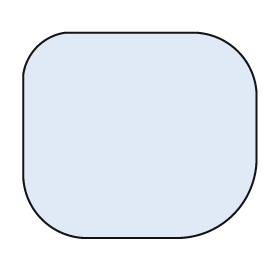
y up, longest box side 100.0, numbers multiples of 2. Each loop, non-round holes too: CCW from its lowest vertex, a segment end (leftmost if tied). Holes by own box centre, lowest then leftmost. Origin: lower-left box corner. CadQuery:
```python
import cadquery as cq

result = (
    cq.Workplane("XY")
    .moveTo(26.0, 0.0)
    .lineTo(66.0, 0.0)
    .threePointArc((90.0, 10.0), (100.0, 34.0))
    .lineTo(100.0, 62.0)
    .threePointArc((92.0, 80.0), (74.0, 88.0))
    .lineTo(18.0, 88.0)
    .threePointArc((6.0, 82.0), (0.0, 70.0))
    .lineTo(0.0, 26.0)
    .threePointArc((8.0, 8.0), (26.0, 0.0))
    .close()
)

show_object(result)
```